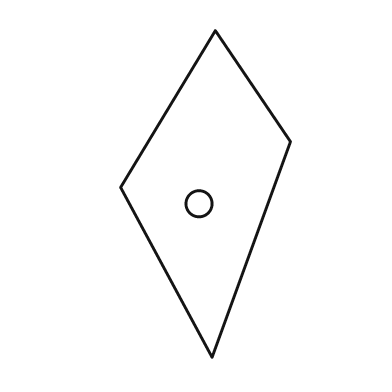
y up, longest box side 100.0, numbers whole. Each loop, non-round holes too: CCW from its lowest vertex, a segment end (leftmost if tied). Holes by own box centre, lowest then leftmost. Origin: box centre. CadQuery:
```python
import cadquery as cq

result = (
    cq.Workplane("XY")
    .moveTo(2.0, -50.0)
    .lineTo(26.0, 16.0)
    .lineTo(3.0, 50.0)
    .lineTo(-26.0, 2.0)
    .close()
    .moveTo(-2.0, -3.0)
    .circle(4.0)
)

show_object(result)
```